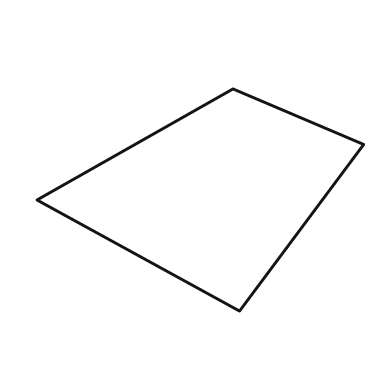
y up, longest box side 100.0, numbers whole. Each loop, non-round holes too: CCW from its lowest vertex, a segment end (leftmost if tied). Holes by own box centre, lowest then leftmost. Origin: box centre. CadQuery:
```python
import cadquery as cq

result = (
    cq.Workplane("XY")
    .moveTo(12.0, -34.0)
    .lineTo(50.0, 17.0)
    .lineTo(10.0, 34.0)
    .lineTo(-50.0, 0.0)
    .close()
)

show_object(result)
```